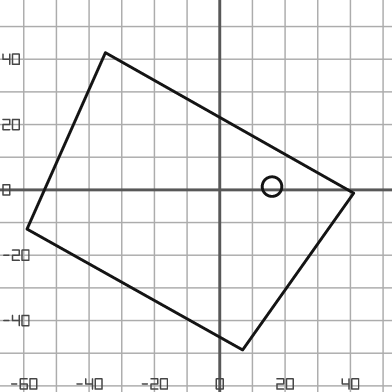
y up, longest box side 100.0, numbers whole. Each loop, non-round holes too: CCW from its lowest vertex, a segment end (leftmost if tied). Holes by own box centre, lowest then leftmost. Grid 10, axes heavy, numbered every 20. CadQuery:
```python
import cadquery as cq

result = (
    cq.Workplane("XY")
    .moveTo(7.0, -49.0)
    .lineTo(41.0, -1.0)
    .lineTo(-35.0, 42.0)
    .lineTo(-59.0, -12.0)
    .close()
    .moveTo(16.0, 1.0)
    .circle(3.0)
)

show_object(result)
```